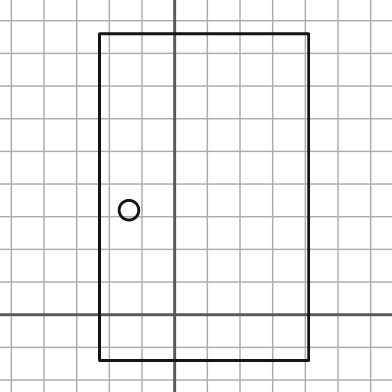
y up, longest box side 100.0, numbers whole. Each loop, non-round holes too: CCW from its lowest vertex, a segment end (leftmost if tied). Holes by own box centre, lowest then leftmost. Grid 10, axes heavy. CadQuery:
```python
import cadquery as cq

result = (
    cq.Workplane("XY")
    .moveTo(-23.0, -14.0)
    .lineTo(41.0, -14.0)
    .lineTo(41.0, 86.0)
    .lineTo(-23.0, 86.0)
    .close()
    .moveTo(-14.0, 32.0)
    .circle(3.0)
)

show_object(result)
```